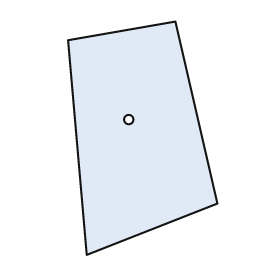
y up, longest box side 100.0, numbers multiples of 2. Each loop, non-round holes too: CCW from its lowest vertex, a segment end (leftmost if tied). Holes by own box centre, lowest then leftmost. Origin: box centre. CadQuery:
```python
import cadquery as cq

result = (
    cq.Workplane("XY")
    .moveTo(-24.0, -50.0)
    .lineTo(32.0, -28.0)
    .lineTo(14.0, 50.0)
    .lineTo(-32.0, 42.0)
    .close()
    .moveTo(-6.0, 8.0)
    .circle(2.0)
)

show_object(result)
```